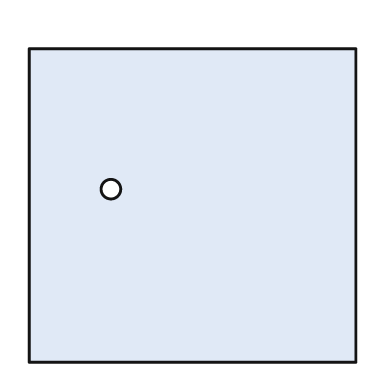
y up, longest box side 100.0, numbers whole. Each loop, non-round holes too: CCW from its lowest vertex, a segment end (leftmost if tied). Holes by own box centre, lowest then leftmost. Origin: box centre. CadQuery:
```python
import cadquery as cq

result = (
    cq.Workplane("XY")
    .moveTo(-50.0, -48.0)
    .lineTo(50.0, -48.0)
    .lineTo(50.0, 48.0)
    .lineTo(-50.0, 48.0)
    .close()
    .moveTo(-25.0, 5.0)
    .circle(3.0)
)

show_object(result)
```